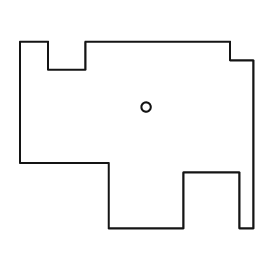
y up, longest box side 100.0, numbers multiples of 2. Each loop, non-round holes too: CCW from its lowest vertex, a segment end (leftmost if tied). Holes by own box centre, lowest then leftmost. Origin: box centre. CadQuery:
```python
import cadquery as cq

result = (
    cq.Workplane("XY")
    .moveTo(-12.0, -40.0)
    .lineTo(20.0, -40.0)
    .lineTo(20.0, -16.0)
    .lineTo(44.0, -16.0)
    .lineTo(44.0, -40.0)
    .lineTo(50.0, -40.0)
    .lineTo(50.0, 32.0)
    .lineTo(40.0, 32.0)
    .lineTo(40.0, 40.0)
    .lineTo(-22.0, 40.0)
    .lineTo(-22.0, 28.0)
    .lineTo(-38.0, 28.0)
    .lineTo(-38.0, 40.0)
    .lineTo(-50.0, 40.0)
    .lineTo(-50.0, -12.0)
    .lineTo(-12.0, -12.0)
    .close()
    .moveTo(4.0, 12.0)
    .circle(2.0)
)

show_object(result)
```